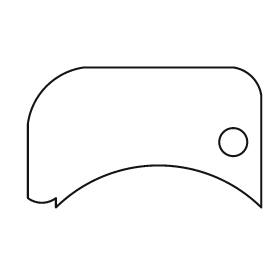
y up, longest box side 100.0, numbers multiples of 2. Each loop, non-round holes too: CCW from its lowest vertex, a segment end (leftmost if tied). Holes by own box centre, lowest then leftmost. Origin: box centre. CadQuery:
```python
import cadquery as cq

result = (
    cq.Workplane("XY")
    .moveTo(-38.0, -30.0)
    .threePointArc((6.0, -12.0), (50.0, -30.0))
    .lineTo(50.0, 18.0)
    .threePointArc((46.0, 26.0), (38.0, 30.0))
    .lineTo(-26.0, 30.0)
    .threePointArc((-42.0, 22.0), (-50.0, 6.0))
    .lineTo(-50.0, -26.0)
    .threePointArc((-44.0, -28.0), (-38.0, -26.0))
    .close()
    .moveTo(38.0, -2.0)
    .circle(6.0)
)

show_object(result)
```